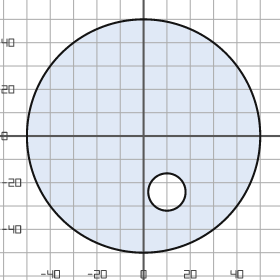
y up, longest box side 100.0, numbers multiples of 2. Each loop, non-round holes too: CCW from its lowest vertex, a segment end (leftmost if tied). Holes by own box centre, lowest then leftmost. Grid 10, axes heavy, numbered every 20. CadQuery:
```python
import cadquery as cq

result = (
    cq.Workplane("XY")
    .moveTo(0.0, 0.0)
    .circle(50.0)
    .moveTo(10.0, -24.0)
    .circle(8.0)
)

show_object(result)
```